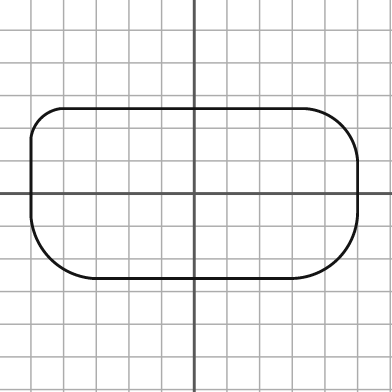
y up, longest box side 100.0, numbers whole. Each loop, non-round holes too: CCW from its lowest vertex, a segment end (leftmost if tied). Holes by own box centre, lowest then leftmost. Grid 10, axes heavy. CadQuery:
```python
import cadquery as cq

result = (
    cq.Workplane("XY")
    .moveTo(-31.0, -26.0)
    .lineTo(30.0, -26.0)
    .threePointArc((44.0, -20.0), (50.0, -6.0))
    .lineTo(50.0, 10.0)
    .threePointArc((45.0, 21.0), (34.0, 26.0))
    .lineTo(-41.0, 26.0)
    .threePointArc((-47.0, 23.0), (-50.0, 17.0))
    .lineTo(-50.0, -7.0)
    .threePointArc((-44.0, -20.0), (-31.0, -26.0))
    .close()
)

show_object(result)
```